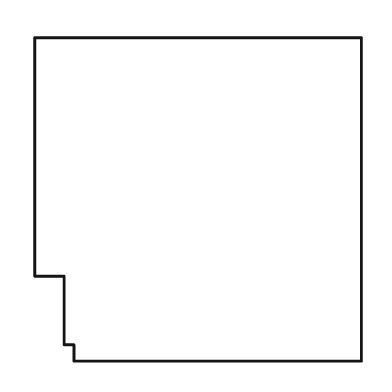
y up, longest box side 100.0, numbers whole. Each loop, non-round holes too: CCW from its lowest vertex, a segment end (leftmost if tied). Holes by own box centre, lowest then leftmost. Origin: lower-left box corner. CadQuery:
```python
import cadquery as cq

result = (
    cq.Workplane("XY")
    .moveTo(12.0, 0.0)
    .lineTo(100.0, 0.0)
    .lineTo(100.0, 99.0)
    .lineTo(0.0, 99.0)
    .lineTo(0.0, 26.0)
    .lineTo(9.0, 26.0)
    .lineTo(9.0, 5.0)
    .lineTo(12.0, 5.0)
    .close()
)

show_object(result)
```